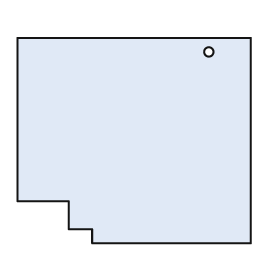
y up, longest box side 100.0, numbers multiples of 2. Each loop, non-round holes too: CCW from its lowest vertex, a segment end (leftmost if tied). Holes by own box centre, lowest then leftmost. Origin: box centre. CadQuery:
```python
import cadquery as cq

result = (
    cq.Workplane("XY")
    .moveTo(-18.0, -44.0)
    .lineTo(50.0, -44.0)
    .lineTo(50.0, 44.0)
    .lineTo(-50.0, 44.0)
    .lineTo(-50.0, -26.0)
    .lineTo(-28.0, -26.0)
    .lineTo(-28.0, -38.0)
    .lineTo(-18.0, -38.0)
    .close()
    .moveTo(32.0, 38.0)
    .circle(2.0)
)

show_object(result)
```